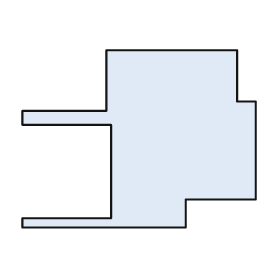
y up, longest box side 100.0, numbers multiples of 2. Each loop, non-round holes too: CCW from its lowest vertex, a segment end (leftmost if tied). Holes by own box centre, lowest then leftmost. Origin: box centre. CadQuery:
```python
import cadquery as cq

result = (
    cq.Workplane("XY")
    .moveTo(-50.0, -38.0)
    .lineTo(20.0, -38.0)
    .lineTo(20.0, -26.0)
    .lineTo(50.0, -26.0)
    .lineTo(50.0, 16.0)
    .lineTo(42.0, 16.0)
    .lineTo(42.0, 38.0)
    .lineTo(-14.0, 38.0)
    .lineTo(-14.0, 12.0)
    .lineTo(-50.0, 12.0)
    .lineTo(-50.0, 6.0)
    .lineTo(-12.0, 6.0)
    .lineTo(-12.0, -34.0)
    .lineTo(-50.0, -34.0)
    .close()
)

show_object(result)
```